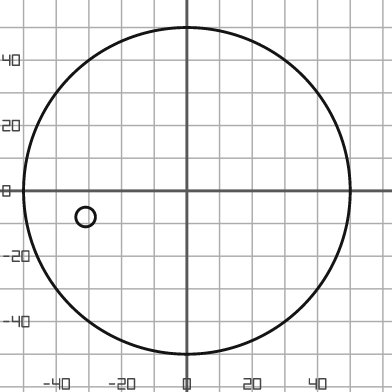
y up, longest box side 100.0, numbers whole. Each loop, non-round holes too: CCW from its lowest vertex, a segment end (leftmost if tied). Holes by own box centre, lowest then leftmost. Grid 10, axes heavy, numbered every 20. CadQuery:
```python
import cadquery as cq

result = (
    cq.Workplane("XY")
    .moveTo(0.0, 0.0)
    .circle(50.0)
    .moveTo(-31.0, -8.0)
    .circle(3.0)
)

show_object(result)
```